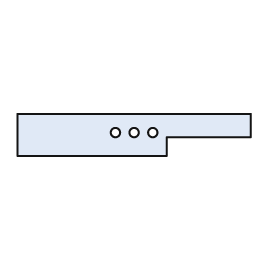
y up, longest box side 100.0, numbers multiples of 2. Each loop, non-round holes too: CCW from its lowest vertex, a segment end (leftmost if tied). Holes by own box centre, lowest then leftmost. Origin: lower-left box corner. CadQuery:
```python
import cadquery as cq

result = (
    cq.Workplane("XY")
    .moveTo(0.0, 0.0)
    .lineTo(64.0, 0.0)
    .lineTo(64.0, 8.0)
    .lineTo(100.0, 8.0)
    .lineTo(100.0, 18.0)
    .lineTo(0.0, 18.0)
    .close()
    .moveTo(42.0, 10.0)
    .circle(2.0)
    .moveTo(50.0, 10.0)
    .circle(2.0)
    .moveTo(58.0, 10.0)
    .circle(2.0)
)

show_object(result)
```